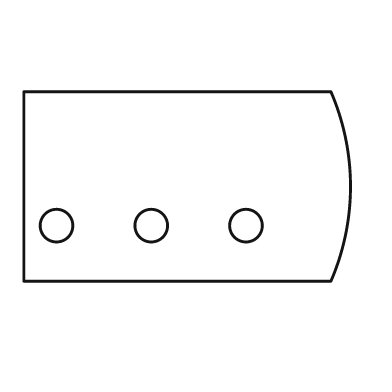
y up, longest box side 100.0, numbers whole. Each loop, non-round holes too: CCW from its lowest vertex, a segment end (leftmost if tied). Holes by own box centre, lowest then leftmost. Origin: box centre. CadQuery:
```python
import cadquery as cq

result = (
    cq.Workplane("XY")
    .moveTo(-50.0, -29.0)
    .lineTo(44.0, -29.0)
    .threePointArc((50.0, 0.0), (44.0, 29.0))
    .lineTo(-50.0, 29.0)
    .close()
    .moveTo(-40.0, -12.0)
    .circle(5.0)
    .moveTo(-11.0, -12.0)
    .circle(5.0)
    .moveTo(18.0, -12.0)
    .circle(5.0)
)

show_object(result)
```